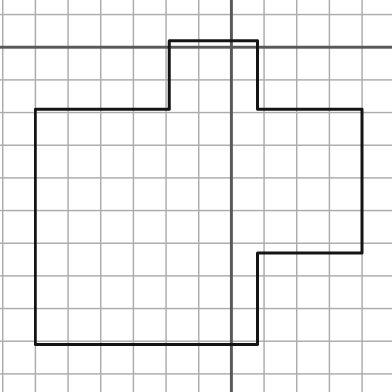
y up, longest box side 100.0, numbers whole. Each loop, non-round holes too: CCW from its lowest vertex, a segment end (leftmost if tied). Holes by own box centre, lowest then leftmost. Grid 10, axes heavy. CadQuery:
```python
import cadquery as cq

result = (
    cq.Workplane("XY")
    .moveTo(-60.0, -91.0)
    .lineTo(8.0, -91.0)
    .lineTo(8.0, -63.0)
    .lineTo(40.0, -63.0)
    .lineTo(40.0, -19.0)
    .lineTo(8.0, -19.0)
    .lineTo(8.0, 2.0)
    .lineTo(-19.0, 2.0)
    .lineTo(-19.0, -19.0)
    .lineTo(-60.0, -19.0)
    .close()
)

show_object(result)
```